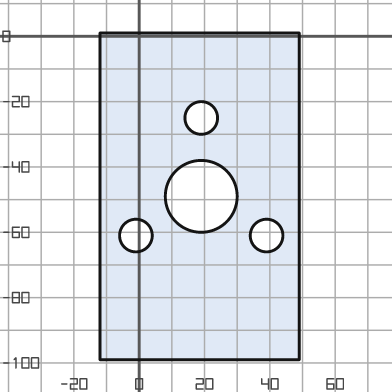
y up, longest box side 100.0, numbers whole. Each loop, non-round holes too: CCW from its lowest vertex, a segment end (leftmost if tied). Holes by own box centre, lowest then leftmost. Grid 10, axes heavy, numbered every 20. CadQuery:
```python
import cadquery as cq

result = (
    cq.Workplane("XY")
    .moveTo(-12.0, -99.0)
    .lineTo(49.0, -99.0)
    .lineTo(49.0, 1.0)
    .lineTo(-12.0, 1.0)
    .close()
    .moveTo(-1.0, -61.0)
    .circle(5.0)
    .moveTo(39.0, -61.0)
    .circle(5.0)
    .moveTo(19.0, -49.0)
    .circle(11.0)
    .moveTo(19.0, -25.0)
    .circle(5.0)
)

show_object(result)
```